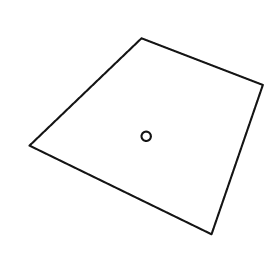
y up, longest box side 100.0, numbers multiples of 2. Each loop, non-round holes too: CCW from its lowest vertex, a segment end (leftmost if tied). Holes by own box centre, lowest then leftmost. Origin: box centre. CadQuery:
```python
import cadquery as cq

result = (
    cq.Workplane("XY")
    .moveTo(28.0, -42.0)
    .lineTo(50.0, 22.0)
    .lineTo(-2.0, 42.0)
    .lineTo(-50.0, -4.0)
    .close()
    .moveTo(0.0, 0.0)
    .circle(2.0)
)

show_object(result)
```